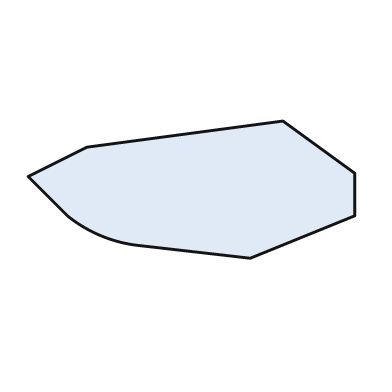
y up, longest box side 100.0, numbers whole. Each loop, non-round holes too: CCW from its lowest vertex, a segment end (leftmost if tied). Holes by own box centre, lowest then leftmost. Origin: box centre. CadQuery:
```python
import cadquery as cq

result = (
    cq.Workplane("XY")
    .moveTo(18.0, -21.0)
    .lineTo(50.0, -8.0)
    .lineTo(50.0, 5.0)
    .lineTo(28.0, 21.0)
    .lineTo(-32.0, 13.0)
    .lineTo(-50.0, 4.0)
    .lineTo(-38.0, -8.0)
    .threePointArc((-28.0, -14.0), (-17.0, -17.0))
    .close()
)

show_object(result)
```